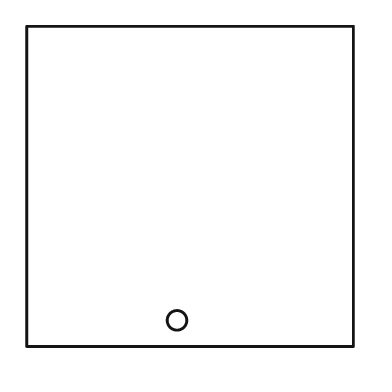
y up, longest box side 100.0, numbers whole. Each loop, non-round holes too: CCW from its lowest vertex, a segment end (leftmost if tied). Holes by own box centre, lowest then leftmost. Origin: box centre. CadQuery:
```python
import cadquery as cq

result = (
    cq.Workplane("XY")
    .moveTo(-50.0, -49.0)
    .lineTo(50.0, -49.0)
    .lineTo(50.0, 49.0)
    .lineTo(-50.0, 49.0)
    .close()
    .moveTo(-4.0, -41.0)
    .circle(3.0)
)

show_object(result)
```